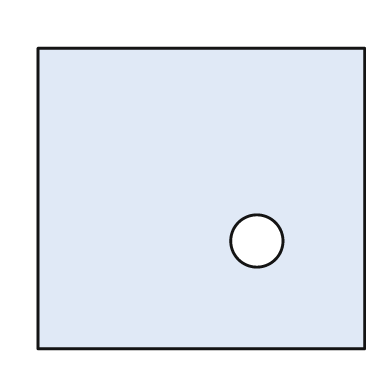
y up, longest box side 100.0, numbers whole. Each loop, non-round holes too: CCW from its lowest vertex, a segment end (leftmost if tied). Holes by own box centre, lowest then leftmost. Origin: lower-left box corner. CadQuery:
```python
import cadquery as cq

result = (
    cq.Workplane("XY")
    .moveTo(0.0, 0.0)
    .lineTo(100.0, 0.0)
    .lineTo(100.0, 92.0)
    .lineTo(0.0, 92.0)
    .close()
    .moveTo(67.0, 33.0)
    .circle(8.0)
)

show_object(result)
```